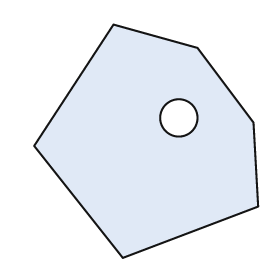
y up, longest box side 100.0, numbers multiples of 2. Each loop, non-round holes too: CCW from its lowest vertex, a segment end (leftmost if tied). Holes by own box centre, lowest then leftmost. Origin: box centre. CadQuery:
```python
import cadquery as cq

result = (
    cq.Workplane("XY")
    .moveTo(-10.0, -50.0)
    .lineTo(48.0, -28.0)
    .lineTo(46.0, 8.0)
    .lineTo(22.0, 40.0)
    .lineTo(-14.0, 50.0)
    .lineTo(-48.0, -2.0)
    .close()
    .moveTo(14.0, 10.0)
    .circle(8.0)
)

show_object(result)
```